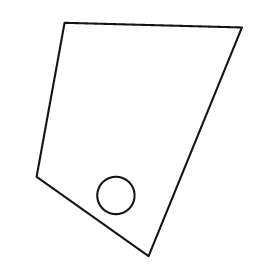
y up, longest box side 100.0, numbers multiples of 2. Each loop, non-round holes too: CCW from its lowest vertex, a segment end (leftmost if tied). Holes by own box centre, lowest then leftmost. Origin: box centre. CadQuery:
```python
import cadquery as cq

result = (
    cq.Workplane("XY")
    .moveTo(4.0, -50.0)
    .lineTo(44.0, 48.0)
    .lineTo(-32.0, 50.0)
    .lineTo(-44.0, -16.0)
    .close()
    .moveTo(-10.0, -24.0)
    .circle(8.0)
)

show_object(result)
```